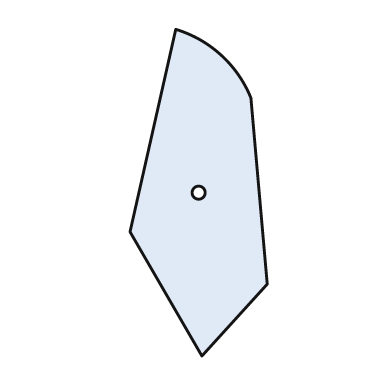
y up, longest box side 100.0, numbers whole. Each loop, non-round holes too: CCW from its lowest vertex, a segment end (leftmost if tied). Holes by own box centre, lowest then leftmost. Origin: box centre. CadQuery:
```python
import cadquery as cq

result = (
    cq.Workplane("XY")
    .moveTo(1.0, -50.0)
    .lineTo(21.0, -28.0)
    .lineTo(16.0, 29.0)
    .threePointArc((7.0, 42.0), (-7.0, 50.0))
    .lineTo(-21.0, -12.0)
    .close()
    .moveTo(0.0, 0.0)
    .circle(2.0)
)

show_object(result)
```